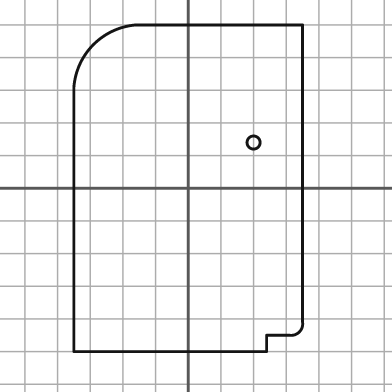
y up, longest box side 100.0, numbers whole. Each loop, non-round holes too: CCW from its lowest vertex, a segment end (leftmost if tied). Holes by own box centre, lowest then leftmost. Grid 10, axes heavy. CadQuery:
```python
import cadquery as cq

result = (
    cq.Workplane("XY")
    .moveTo(-35.0, -50.0)
    .lineTo(24.0, -50.0)
    .lineTo(24.0, -45.0)
    .lineTo(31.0, -45.0)
    .threePointArc((34.0, -44.0), (35.0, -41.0))
    .lineTo(35.0, 50.0)
    .lineTo(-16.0, 50.0)
    .threePointArc((-29.0, 44.0), (-35.0, 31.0))
    .close()
    .moveTo(20.0, 14.0)
    .circle(2.0)
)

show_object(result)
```